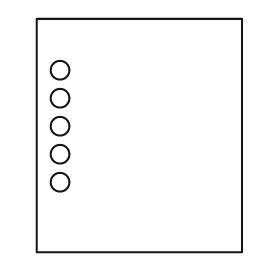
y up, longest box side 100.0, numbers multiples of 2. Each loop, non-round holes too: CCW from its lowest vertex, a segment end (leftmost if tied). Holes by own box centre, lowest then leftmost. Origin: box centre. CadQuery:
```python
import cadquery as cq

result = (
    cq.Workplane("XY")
    .moveTo(-44.0, -50.0)
    .lineTo(44.0, -50.0)
    .lineTo(44.0, 50.0)
    .lineTo(-44.0, 50.0)
    .close()
    .moveTo(-34.0, -20.0)
    .circle(4.0)
    .moveTo(-34.0, -8.0)
    .circle(4.0)
    .moveTo(-34.0, 4.0)
    .circle(4.0)
    .moveTo(-34.0, 16.0)
    .circle(4.0)
    .moveTo(-34.0, 28.0)
    .circle(4.0)
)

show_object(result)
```